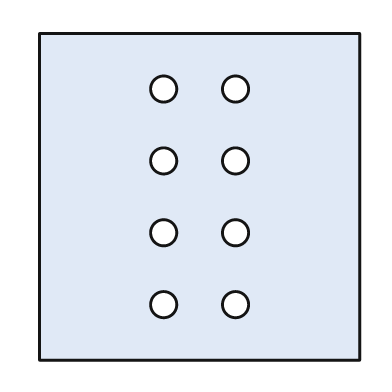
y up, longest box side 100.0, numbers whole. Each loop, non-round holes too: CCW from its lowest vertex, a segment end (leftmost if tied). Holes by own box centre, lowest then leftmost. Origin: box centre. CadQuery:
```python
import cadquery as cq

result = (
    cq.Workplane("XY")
    .moveTo(-49.0, -50.0)
    .lineTo(49.0, -50.0)
    .lineTo(49.0, 50.0)
    .lineTo(-49.0, 50.0)
    .close()
    .moveTo(-11.0, -33.0)
    .circle(4.0)
    .moveTo(11.0, -33.0)
    .circle(4.0)
    .moveTo(-11.0, -11.0)
    .circle(4.0)
    .moveTo(11.0, -11.0)
    .circle(4.0)
    .moveTo(-11.0, 11.0)
    .circle(4.0)
    .moveTo(11.0, 11.0)
    .circle(4.0)
    .moveTo(-11.0, 33.0)
    .circle(4.0)
    .moveTo(11.0, 33.0)
    .circle(4.0)
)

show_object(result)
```